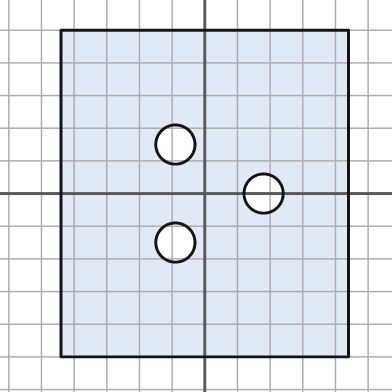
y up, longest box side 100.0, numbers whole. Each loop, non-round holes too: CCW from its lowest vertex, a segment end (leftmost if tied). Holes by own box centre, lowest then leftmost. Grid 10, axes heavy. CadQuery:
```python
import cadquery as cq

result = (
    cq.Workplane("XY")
    .moveTo(-44.0, -50.0)
    .lineTo(44.0, -50.0)
    .lineTo(44.0, 50.0)
    .lineTo(-44.0, 50.0)
    .close()
    .moveTo(-9.0, -15.0)
    .circle(6.0)
    .moveTo(18.0, 0.0)
    .circle(6.0)
    .moveTo(-9.0, 15.0)
    .circle(6.0)
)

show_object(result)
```